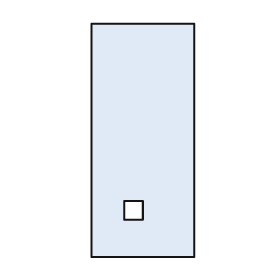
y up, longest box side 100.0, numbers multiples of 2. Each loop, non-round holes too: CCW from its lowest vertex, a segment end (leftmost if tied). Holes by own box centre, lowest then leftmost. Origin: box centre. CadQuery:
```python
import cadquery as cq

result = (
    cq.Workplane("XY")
    .moveTo(-22.0, -50.0)
    .lineTo(22.0, -50.0)
    .lineTo(22.0, 50.0)
    .lineTo(-22.0, 50.0)
    .close()
    .moveTo(-8.0, -34.0)
    .lineTo(0.0, -34.0)
    .lineTo(0.0, -26.0)
    .lineTo(-8.0, -26.0)
    .close()
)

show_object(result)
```